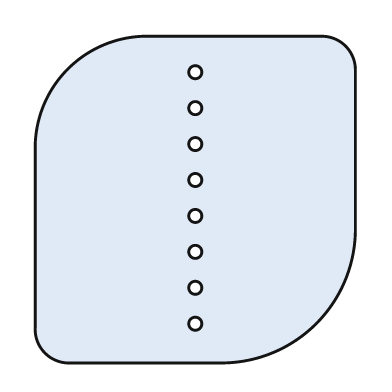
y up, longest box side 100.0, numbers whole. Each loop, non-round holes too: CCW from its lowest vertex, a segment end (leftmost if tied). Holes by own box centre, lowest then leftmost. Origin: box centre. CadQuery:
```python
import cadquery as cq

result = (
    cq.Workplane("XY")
    .moveTo(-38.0, -50.0)
    .lineTo(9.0, -50.0)
    .threePointArc((37.0, -38.0), (49.0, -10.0))
    .lineTo(49.0, 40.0)
    .threePointArc((46.0, 47.0), (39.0, 50.0))
    .lineTo(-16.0, 50.0)
    .threePointArc((-39.0, 40.0), (-49.0, 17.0))
    .lineTo(-49.0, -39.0)
    .threePointArc((-46.0, -47.0), (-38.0, -50.0))
    .close()
    .moveTo(0.0, -38.0)
    .circle(2.0)
    .moveTo(0.0, -27.0)
    .circle(2.0)
    .moveTo(0.0, -16.0)
    .circle(2.0)
    .moveTo(0.0, -5.0)
    .circle(2.0)
    .moveTo(0.0, 6.0)
    .circle(2.0)
    .moveTo(0.0, 17.0)
    .circle(2.0)
    .moveTo(0.0, 28.0)
    .circle(2.0)
    .moveTo(0.0, 39.0)
    .circle(2.0)
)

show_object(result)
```